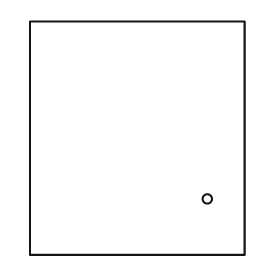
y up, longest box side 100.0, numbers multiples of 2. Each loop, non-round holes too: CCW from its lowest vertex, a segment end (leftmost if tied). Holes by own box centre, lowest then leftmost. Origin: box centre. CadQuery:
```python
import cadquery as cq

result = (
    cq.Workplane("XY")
    .moveTo(-46.0, -50.0)
    .lineTo(46.0, -50.0)
    .lineTo(46.0, 50.0)
    .lineTo(-46.0, 50.0)
    .close()
    .moveTo(30.0, -26.0)
    .circle(2.0)
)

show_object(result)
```